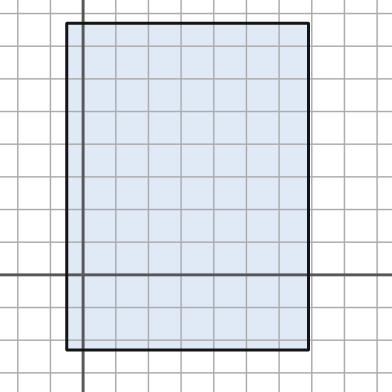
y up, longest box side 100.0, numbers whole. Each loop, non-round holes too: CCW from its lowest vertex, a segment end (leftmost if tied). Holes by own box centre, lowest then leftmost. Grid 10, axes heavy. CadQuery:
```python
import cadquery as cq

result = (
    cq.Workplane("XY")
    .moveTo(-5.0, -23.0)
    .lineTo(69.0, -23.0)
    .lineTo(69.0, 77.0)
    .lineTo(-5.0, 77.0)
    .close()
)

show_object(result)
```